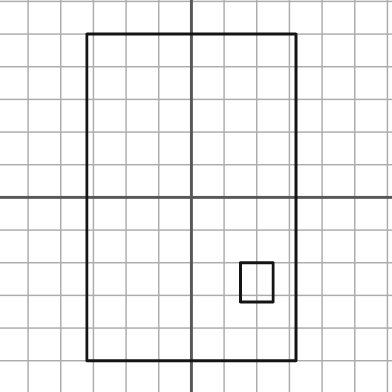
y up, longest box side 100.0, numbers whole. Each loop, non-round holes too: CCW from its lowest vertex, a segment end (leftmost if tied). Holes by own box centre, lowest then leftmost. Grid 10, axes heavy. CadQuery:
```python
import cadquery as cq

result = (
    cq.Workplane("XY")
    .moveTo(-32.0, -50.0)
    .lineTo(32.0, -50.0)
    .lineTo(32.0, 50.0)
    .lineTo(-32.0, 50.0)
    .close()
    .moveTo(15.0, -32.0)
    .lineTo(25.0, -32.0)
    .lineTo(25.0, -20.0)
    .lineTo(15.0, -20.0)
    .close()
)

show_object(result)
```